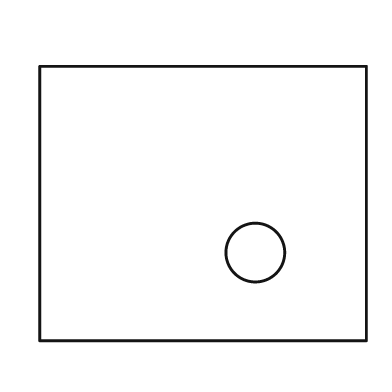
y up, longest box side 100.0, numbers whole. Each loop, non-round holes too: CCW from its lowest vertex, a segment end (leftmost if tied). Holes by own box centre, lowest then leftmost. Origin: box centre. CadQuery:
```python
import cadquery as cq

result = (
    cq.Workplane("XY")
    .moveTo(-50.0, -42.0)
    .lineTo(50.0, -42.0)
    .lineTo(50.0, 42.0)
    .lineTo(-50.0, 42.0)
    .close()
    .moveTo(16.0, -15.0)
    .circle(9.0)
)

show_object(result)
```